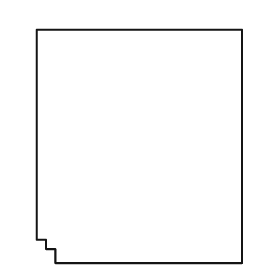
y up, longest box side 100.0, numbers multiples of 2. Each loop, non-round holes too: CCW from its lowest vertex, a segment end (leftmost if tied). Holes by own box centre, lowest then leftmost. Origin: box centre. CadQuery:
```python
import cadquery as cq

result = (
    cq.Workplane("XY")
    .moveTo(-36.0, -50.0)
    .lineTo(44.0, -50.0)
    .lineTo(44.0, 50.0)
    .lineTo(-44.0, 50.0)
    .lineTo(-44.0, -40.0)
    .lineTo(-40.0, -40.0)
    .lineTo(-40.0, -44.0)
    .lineTo(-36.0, -44.0)
    .close()
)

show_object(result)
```